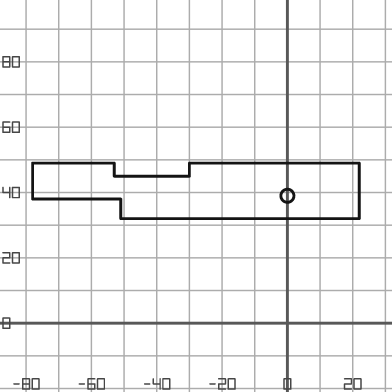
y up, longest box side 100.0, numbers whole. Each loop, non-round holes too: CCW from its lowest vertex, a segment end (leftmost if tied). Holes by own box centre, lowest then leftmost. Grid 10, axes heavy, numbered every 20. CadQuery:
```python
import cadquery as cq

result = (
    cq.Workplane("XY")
    .moveTo(-51.0, 32.0)
    .lineTo(22.0, 32.0)
    .lineTo(22.0, 49.0)
    .lineTo(-30.0, 49.0)
    .lineTo(-30.0, 45.0)
    .lineTo(-53.0, 45.0)
    .lineTo(-53.0, 49.0)
    .lineTo(-78.0, 49.0)
    .lineTo(-78.0, 38.0)
    .lineTo(-51.0, 38.0)
    .close()
    .moveTo(0.0, 39.0)
    .circle(2.0)
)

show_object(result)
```